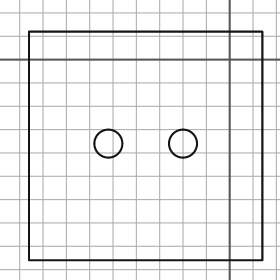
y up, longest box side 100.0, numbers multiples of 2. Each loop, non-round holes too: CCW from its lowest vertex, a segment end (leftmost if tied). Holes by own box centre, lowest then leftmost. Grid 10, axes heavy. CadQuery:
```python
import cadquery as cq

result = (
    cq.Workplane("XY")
    .moveTo(-86.0, -86.0)
    .lineTo(14.0, -86.0)
    .lineTo(14.0, 12.0)
    .lineTo(-86.0, 12.0)
    .close()
    .moveTo(-52.0, -36.0)
    .circle(6.0)
    .moveTo(-20.0, -36.0)
    .circle(6.0)
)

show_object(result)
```